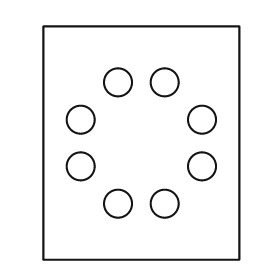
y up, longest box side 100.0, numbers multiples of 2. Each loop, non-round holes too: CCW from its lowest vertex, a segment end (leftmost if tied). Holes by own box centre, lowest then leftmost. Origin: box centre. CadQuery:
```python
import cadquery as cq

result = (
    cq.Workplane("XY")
    .moveTo(-42.0, -50.0)
    .lineTo(42.0, -50.0)
    .lineTo(42.0, 50.0)
    .lineTo(-42.0, 50.0)
    .close()
    .moveTo(-10.0, -26.0)
    .circle(6.0)
    .moveTo(10.0, -26.0)
    .circle(6.0)
    .moveTo(-26.0, -10.0)
    .circle(6.0)
    .moveTo(26.0, -10.0)
    .circle(6.0)
    .moveTo(-26.0, 10.0)
    .circle(6.0)
    .moveTo(26.0, 10.0)
    .circle(6.0)
    .moveTo(-10.0, 26.0)
    .circle(6.0)
    .moveTo(10.0, 26.0)
    .circle(6.0)
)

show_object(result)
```